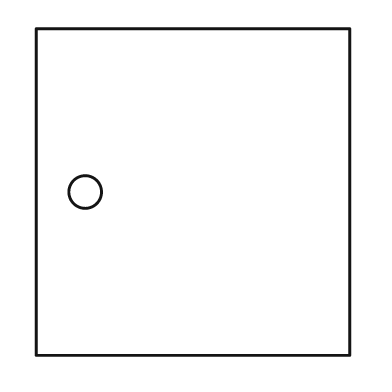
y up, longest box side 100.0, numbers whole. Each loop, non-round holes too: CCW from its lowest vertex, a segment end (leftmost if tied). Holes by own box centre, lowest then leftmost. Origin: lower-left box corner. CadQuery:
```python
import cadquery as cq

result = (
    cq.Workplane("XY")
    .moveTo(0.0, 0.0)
    .lineTo(96.0, 0.0)
    .lineTo(96.0, 100.0)
    .lineTo(0.0, 100.0)
    .close()
    .moveTo(15.0, 50.0)
    .circle(5.0)
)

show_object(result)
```